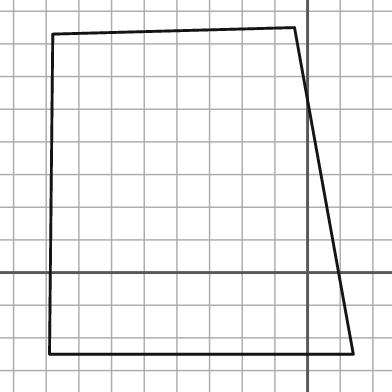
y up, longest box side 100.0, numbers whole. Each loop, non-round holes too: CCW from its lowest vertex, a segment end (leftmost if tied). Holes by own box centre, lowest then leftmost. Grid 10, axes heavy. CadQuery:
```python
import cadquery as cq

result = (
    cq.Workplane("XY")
    .moveTo(-79.0, -25.0)
    .lineTo(14.0, -25.0)
    .lineTo(-4.0, 75.0)
    .lineTo(-78.0, 73.0)
    .close()
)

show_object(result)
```